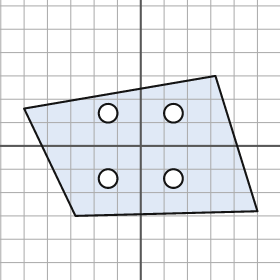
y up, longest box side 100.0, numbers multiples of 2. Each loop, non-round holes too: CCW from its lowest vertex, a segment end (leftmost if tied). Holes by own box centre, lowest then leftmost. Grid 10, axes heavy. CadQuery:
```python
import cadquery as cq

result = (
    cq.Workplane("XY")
    .moveTo(-28.0, -30.0)
    .lineTo(50.0, -28.0)
    .lineTo(32.0, 30.0)
    .lineTo(-50.0, 16.0)
    .close()
    .moveTo(-14.0, -14.0)
    .circle(4.0)
    .moveTo(14.0, -14.0)
    .circle(4.0)
    .moveTo(-14.0, 14.0)
    .circle(4.0)
    .moveTo(14.0, 14.0)
    .circle(4.0)
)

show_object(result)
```